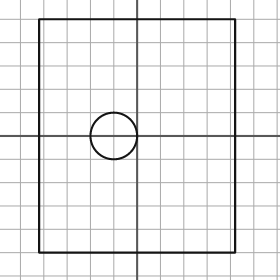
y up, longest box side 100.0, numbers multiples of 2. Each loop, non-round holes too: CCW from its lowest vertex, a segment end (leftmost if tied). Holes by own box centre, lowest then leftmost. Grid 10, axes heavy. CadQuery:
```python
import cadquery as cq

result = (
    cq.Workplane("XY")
    .moveTo(-42.0, -50.0)
    .lineTo(42.0, -50.0)
    .lineTo(42.0, 50.0)
    .lineTo(-42.0, 50.0)
    .close()
    .moveTo(-10.0, 0.0)
    .circle(10.0)
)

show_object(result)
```